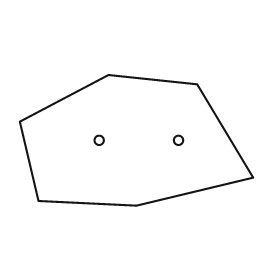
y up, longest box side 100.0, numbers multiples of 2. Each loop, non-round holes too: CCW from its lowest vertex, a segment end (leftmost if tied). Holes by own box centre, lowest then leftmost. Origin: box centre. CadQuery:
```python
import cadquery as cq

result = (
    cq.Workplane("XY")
    .moveTo(0.0, -28.0)
    .lineTo(50.0, -16.0)
    .lineTo(26.0, 24.0)
    .lineTo(-12.0, 28.0)
    .lineTo(-50.0, 8.0)
    .lineTo(-42.0, -26.0)
    .close()
    .moveTo(-16.0, 0.0)
    .circle(2.0)
    .moveTo(18.0, 0.0)
    .circle(2.0)
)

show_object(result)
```